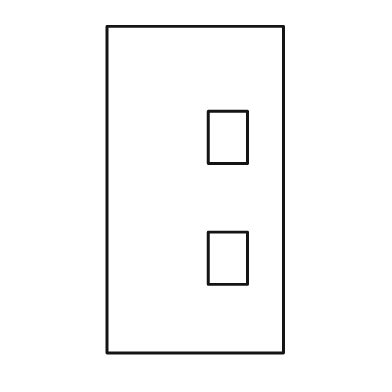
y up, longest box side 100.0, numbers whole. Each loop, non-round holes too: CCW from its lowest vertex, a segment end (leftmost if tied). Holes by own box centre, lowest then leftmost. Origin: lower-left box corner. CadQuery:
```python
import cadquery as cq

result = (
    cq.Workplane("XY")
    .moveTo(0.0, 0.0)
    .lineTo(54.0, 0.0)
    .lineTo(54.0, 100.0)
    .lineTo(0.0, 100.0)
    .close()
    .moveTo(31.0, 21.0)
    .lineTo(43.0, 21.0)
    .lineTo(43.0, 37.0)
    .lineTo(31.0, 37.0)
    .close()
    .moveTo(31.0, 58.0)
    .lineTo(43.0, 58.0)
    .lineTo(43.0, 74.0)
    .lineTo(31.0, 74.0)
    .close()
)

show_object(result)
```